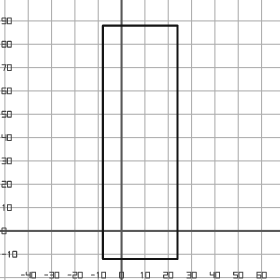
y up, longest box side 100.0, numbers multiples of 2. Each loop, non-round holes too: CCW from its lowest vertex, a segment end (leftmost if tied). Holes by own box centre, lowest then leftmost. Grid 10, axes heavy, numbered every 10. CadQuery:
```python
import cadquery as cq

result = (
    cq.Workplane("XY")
    .moveTo(-8.0, -12.0)
    .lineTo(24.0, -12.0)
    .lineTo(24.0, 88.0)
    .lineTo(-8.0, 88.0)
    .close()
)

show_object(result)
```